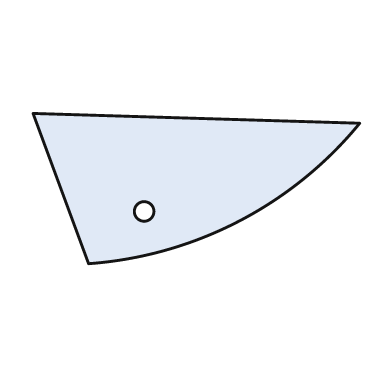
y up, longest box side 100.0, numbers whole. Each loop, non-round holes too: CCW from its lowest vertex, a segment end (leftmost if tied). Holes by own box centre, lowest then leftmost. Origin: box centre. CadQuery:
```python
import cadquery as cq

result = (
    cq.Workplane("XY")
    .moveTo(-33.0, -23.0)
    .threePointArc((13.0, -10.0), (50.0, 20.0))
    .lineTo(-50.0, 23.0)
    .close()
    .moveTo(-16.0, -7.0)
    .circle(3.0)
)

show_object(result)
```